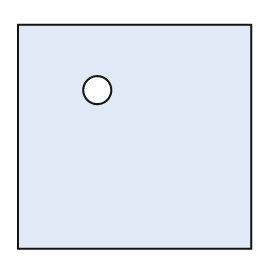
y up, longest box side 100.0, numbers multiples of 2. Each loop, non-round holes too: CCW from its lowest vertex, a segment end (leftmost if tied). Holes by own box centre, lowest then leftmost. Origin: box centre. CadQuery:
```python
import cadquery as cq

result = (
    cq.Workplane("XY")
    .moveTo(-50.0, -48.0)
    .lineTo(50.0, -48.0)
    .lineTo(50.0, 48.0)
    .lineTo(-50.0, 48.0)
    .close()
    .moveTo(-16.0, 20.0)
    .circle(6.0)
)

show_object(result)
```